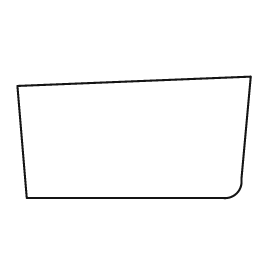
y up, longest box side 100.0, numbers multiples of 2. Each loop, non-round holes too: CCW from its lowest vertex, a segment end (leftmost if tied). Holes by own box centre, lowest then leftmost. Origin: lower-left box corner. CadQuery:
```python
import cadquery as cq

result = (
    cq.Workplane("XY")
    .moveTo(4.0, 0.0)
    .lineTo(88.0, 0.0)
    .threePointArc((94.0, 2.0), (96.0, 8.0))
    .lineTo(100.0, 52.0)
    .lineTo(0.0, 48.0)
    .close()
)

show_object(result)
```